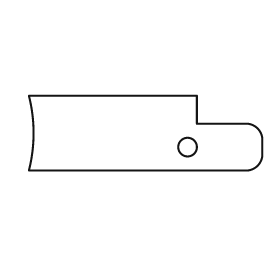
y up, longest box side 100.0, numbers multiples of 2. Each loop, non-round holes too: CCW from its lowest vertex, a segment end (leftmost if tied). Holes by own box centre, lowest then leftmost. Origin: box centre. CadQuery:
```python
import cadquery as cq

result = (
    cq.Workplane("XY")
    .moveTo(-50.0, -16.0)
    .lineTo(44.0, -16.0)
    .threePointArc((48.0, -14.0), (50.0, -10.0))
    .lineTo(50.0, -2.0)
    .threePointArc((48.0, 2.0), (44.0, 4.0))
    .lineTo(22.0, 4.0)
    .lineTo(22.0, 16.0)
    .lineTo(-50.0, 16.0)
    .threePointArc((-48.0, 0.0), (-50.0, -16.0))
    .close()
    .moveTo(18.0, -6.0)
    .circle(4.0)
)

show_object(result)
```